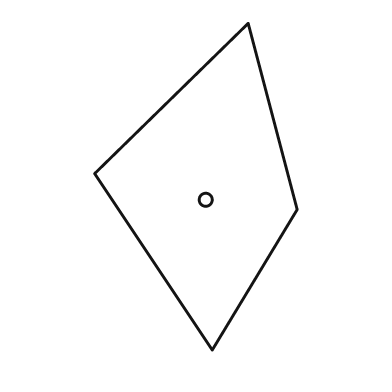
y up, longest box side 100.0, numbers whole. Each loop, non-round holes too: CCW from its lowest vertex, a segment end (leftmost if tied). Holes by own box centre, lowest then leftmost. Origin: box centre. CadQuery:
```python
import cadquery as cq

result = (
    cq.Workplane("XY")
    .moveTo(5.0, -50.0)
    .lineTo(31.0, -7.0)
    .lineTo(16.0, 50.0)
    .lineTo(-31.0, 4.0)
    .close()
    .moveTo(3.0, -4.0)
    .circle(2.0)
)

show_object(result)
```